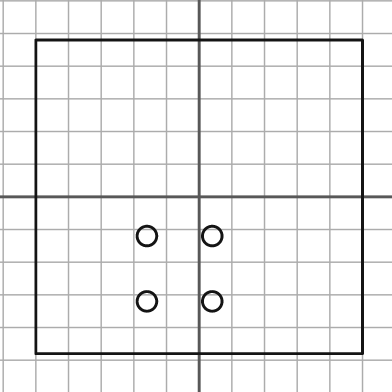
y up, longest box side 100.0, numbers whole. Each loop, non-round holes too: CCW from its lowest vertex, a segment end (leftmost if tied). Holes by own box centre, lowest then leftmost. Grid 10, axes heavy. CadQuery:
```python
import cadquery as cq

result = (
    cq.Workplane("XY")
    .moveTo(-50.0, -48.0)
    .lineTo(50.0, -48.0)
    .lineTo(50.0, 48.0)
    .lineTo(-50.0, 48.0)
    .close()
    .moveTo(-16.0, -32.0)
    .circle(3.0)
    .moveTo(4.0, -32.0)
    .circle(3.0)
    .moveTo(-16.0, -12.0)
    .circle(3.0)
    .moveTo(4.0, -12.0)
    .circle(3.0)
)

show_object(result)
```